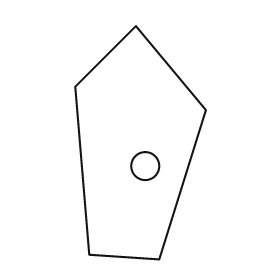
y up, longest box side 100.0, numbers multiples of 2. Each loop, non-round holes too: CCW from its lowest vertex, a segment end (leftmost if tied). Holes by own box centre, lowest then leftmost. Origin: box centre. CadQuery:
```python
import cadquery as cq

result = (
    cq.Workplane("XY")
    .moveTo(8.0, -50.0)
    .lineTo(28.0, 14.0)
    .lineTo(-2.0, 50.0)
    .lineTo(-28.0, 24.0)
    .lineTo(-22.0, -48.0)
    .close()
    .moveTo(2.0, -10.0)
    .circle(6.0)
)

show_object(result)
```